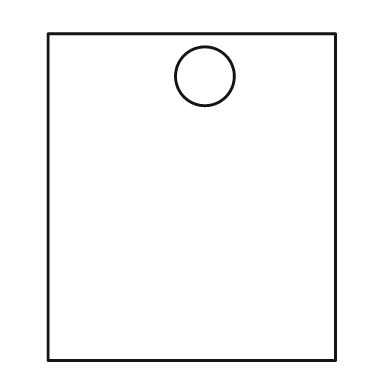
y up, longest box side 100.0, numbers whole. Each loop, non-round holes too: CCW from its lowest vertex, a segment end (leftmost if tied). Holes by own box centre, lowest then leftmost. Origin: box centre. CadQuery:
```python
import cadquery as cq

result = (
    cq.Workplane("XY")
    .moveTo(-44.0, -50.0)
    .lineTo(44.0, -50.0)
    .lineTo(44.0, 50.0)
    .lineTo(-44.0, 50.0)
    .close()
    .moveTo(4.0, 37.0)
    .circle(9.0)
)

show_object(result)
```